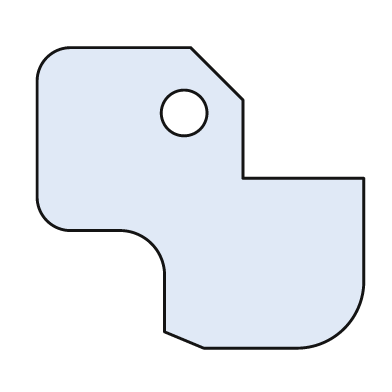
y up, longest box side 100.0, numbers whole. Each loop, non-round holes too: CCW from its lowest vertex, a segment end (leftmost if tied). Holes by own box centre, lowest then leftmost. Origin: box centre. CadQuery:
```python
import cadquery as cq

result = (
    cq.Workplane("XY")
    .moveTo(1.0, -46.0)
    .lineTo(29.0, -46.0)
    .threePointArc((44.0, -40.0), (50.0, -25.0))
    .lineTo(50.0, 6.0)
    .lineTo(13.0, 6.0)
    .lineTo(13.0, 30.0)
    .lineTo(-3.0, 46.0)
    .lineTo(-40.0, 46.0)
    .threePointArc((-47.0, 43.0), (-50.0, 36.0))
    .lineTo(-50.0, 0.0)
    .threePointArc((-47.0, -7.0), (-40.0, -10.0))
    .lineTo(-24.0, -10.0)
    .threePointArc((-15.0, -14.0), (-11.0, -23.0))
    .lineTo(-11.0, -41.0)
    .close()
    .moveTo(-5.0, 26.0)
    .circle(7.0)
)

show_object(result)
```